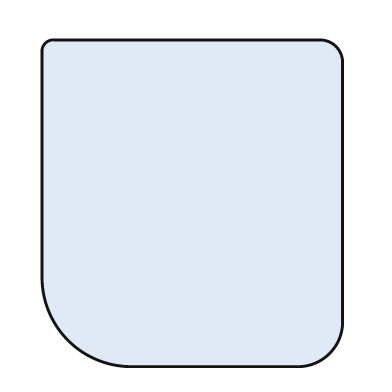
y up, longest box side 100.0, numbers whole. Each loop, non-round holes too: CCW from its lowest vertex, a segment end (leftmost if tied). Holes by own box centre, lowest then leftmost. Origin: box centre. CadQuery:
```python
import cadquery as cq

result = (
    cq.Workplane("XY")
    .moveTo(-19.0, -50.0)
    .lineTo(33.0, -50.0)
    .threePointArc((42.0, -46.0), (46.0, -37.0))
    .lineTo(46.0, 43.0)
    .threePointArc((44.0, 48.0), (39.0, 50.0))
    .lineTo(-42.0, 50.0)
    .threePointArc((-45.0, 49.0), (-46.0, 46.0))
    .lineTo(-46.0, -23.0)
    .threePointArc((-38.0, -42.0), (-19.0, -50.0))
    .close()
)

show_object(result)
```